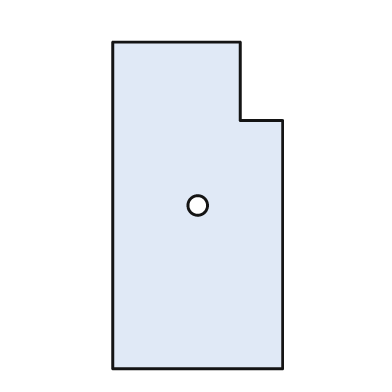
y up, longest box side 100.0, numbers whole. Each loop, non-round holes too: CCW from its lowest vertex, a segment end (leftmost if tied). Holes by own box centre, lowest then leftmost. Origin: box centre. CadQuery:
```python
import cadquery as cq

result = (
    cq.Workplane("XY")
    .moveTo(-26.0, -50.0)
    .lineTo(26.0, -50.0)
    .lineTo(26.0, 26.0)
    .lineTo(13.0, 26.0)
    .lineTo(13.0, 50.0)
    .lineTo(-26.0, 50.0)
    .close()
    .moveTo(0.0, 0.0)
    .circle(3.0)
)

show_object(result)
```